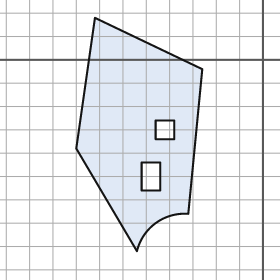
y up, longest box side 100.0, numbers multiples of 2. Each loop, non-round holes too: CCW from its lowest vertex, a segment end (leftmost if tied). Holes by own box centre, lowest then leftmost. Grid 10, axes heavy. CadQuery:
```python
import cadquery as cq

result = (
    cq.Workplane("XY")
    .moveTo(-54.0, -82.0)
    .threePointArc((-46.0, -70.0), (-32.0, -66.0))
    .lineTo(-26.0, -4.0)
    .lineTo(-72.0, 18.0)
    .lineTo(-80.0, -38.0)
    .close()
    .moveTo(-52.0, -56.0)
    .lineTo(-44.0, -56.0)
    .lineTo(-44.0, -44.0)
    .lineTo(-52.0, -44.0)
    .close()
    .moveTo(-46.0, -34.0)
    .lineTo(-38.0, -34.0)
    .lineTo(-38.0, -26.0)
    .lineTo(-46.0, -26.0)
    .close()
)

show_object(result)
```